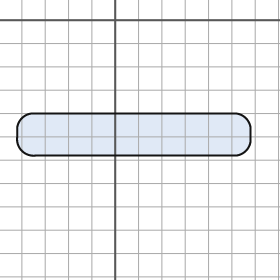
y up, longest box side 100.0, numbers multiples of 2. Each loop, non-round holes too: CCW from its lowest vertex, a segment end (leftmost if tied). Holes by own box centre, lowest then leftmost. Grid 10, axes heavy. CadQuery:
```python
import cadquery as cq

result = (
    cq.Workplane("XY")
    .moveTo(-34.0, -58.0)
    .lineTo(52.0, -58.0)
    .threePointArc((56.0, -56.0), (58.0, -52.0))
    .lineTo(58.0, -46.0)
    .threePointArc((56.0, -42.0), (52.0, -40.0))
    .lineTo(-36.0, -40.0)
    .threePointArc((-40.0, -42.0), (-42.0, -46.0))
    .lineTo(-42.0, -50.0)
    .threePointArc((-40.0, -56.0), (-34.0, -58.0))
    .close()
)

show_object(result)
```